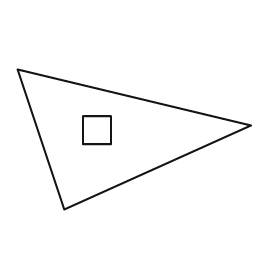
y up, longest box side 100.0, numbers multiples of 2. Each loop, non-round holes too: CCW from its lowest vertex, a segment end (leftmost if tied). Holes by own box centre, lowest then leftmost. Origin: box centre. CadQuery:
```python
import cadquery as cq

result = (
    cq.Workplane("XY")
    .moveTo(-30.0, -30.0)
    .lineTo(50.0, 6.0)
    .lineTo(-50.0, 30.0)
    .close()
    .moveTo(-22.0, -2.0)
    .lineTo(-10.0, -2.0)
    .lineTo(-10.0, 10.0)
    .lineTo(-22.0, 10.0)
    .close()
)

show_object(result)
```